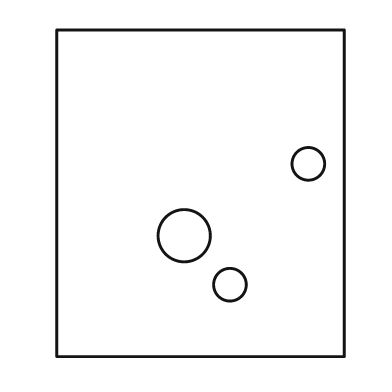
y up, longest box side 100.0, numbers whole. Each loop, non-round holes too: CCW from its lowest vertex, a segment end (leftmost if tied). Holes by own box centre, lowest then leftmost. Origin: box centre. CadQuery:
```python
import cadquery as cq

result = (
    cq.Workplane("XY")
    .moveTo(-44.0, -50.0)
    .lineTo(44.0, -50.0)
    .lineTo(44.0, 50.0)
    .lineTo(-44.0, 50.0)
    .close()
    .moveTo(9.0, -28.0)
    .circle(5.0)
    .moveTo(-5.0, -13.0)
    .circle(8.0)
    .moveTo(33.0, 9.0)
    .circle(5.0)
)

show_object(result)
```